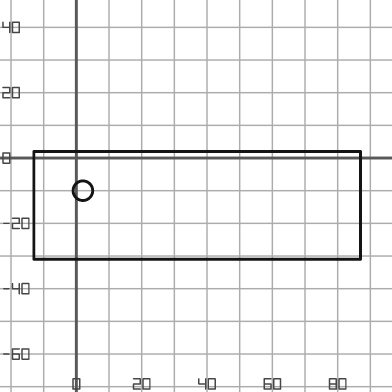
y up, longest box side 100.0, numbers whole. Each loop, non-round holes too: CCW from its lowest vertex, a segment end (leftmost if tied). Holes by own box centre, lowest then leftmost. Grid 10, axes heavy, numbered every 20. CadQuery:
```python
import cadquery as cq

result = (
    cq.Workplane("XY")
    .moveTo(-13.0, -31.0)
    .lineTo(87.0, -31.0)
    .lineTo(87.0, 2.0)
    .lineTo(-13.0, 2.0)
    .close()
    .moveTo(2.0, -10.0)
    .circle(3.0)
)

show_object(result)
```